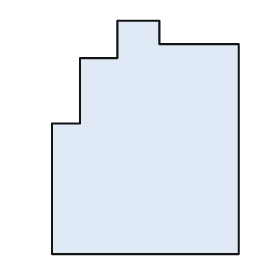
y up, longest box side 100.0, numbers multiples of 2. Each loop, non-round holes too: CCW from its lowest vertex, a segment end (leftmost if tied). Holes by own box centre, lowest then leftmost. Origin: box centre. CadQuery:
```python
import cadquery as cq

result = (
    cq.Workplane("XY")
    .moveTo(-40.0, -50.0)
    .lineTo(40.0, -50.0)
    .lineTo(40.0, 40.0)
    .lineTo(6.0, 40.0)
    .lineTo(6.0, 50.0)
    .lineTo(-12.0, 50.0)
    .lineTo(-12.0, 34.0)
    .lineTo(-28.0, 34.0)
    .lineTo(-28.0, 6.0)
    .lineTo(-40.0, 6.0)
    .close()
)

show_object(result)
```